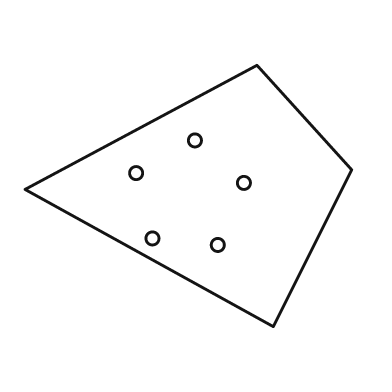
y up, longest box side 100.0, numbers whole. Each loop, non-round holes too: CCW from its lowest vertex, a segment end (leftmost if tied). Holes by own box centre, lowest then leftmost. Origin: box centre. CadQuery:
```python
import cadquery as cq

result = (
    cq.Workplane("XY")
    .moveTo(26.0, -40.0)
    .lineTo(50.0, 8.0)
    .lineTo(21.0, 40.0)
    .lineTo(-50.0, 2.0)
    .close()
    .moveTo(9.0, -15.0)
    .circle(2.0)
    .moveTo(-11.0, -13.0)
    .circle(2.0)
    .moveTo(17.0, 4.0)
    .circle(2.0)
    .moveTo(-16.0, 7.0)
    .circle(2.0)
    .moveTo(2.0, 17.0)
    .circle(2.0)
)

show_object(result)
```